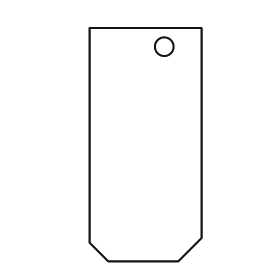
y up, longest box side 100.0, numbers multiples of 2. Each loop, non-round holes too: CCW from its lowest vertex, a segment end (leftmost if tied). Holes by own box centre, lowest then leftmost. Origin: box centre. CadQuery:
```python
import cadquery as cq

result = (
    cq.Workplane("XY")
    .moveTo(-16.0, -50.0)
    .lineTo(14.0, -50.0)
    .lineTo(24.0, -40.0)
    .lineTo(24.0, 50.0)
    .lineTo(-24.0, 50.0)
    .lineTo(-24.0, -42.0)
    .close()
    .moveTo(8.0, 42.0)
    .circle(4.0)
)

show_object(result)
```